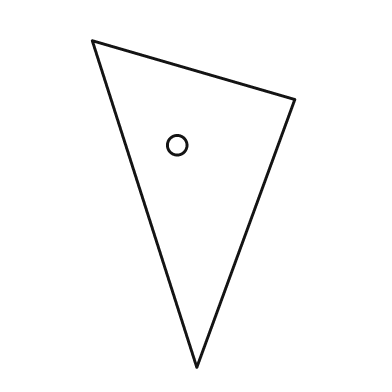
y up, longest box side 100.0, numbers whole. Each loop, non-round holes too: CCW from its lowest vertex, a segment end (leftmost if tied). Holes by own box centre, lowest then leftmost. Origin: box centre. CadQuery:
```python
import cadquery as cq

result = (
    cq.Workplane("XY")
    .moveTo(1.0, -50.0)
    .lineTo(31.0, 32.0)
    .lineTo(-31.0, 50.0)
    .close()
    .moveTo(-5.0, 18.0)
    .circle(3.0)
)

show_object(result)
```